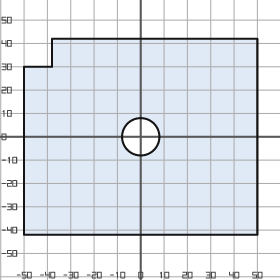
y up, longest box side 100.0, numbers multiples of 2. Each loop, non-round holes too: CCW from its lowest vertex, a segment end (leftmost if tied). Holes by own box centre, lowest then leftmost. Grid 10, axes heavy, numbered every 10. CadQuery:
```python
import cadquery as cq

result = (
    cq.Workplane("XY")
    .moveTo(-50.0, -42.0)
    .lineTo(50.0, -42.0)
    .lineTo(50.0, 42.0)
    .lineTo(-38.0, 42.0)
    .lineTo(-38.0, 30.0)
    .lineTo(-50.0, 30.0)
    .close()
    .moveTo(0.0, 0.0)
    .circle(8.0)
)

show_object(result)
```